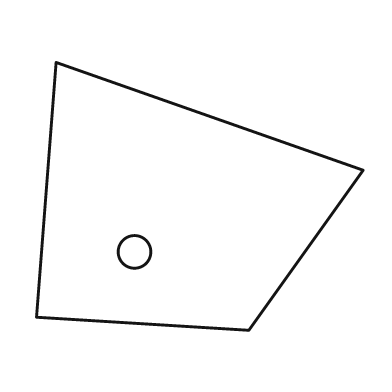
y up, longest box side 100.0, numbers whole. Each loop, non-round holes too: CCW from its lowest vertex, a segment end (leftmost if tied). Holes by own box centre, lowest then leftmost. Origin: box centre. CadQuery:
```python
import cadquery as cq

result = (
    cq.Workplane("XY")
    .moveTo(15.0, -41.0)
    .lineTo(50.0, 8.0)
    .lineTo(-44.0, 41.0)
    .lineTo(-50.0, -37.0)
    .close()
    .moveTo(-20.0, -17.0)
    .circle(5.0)
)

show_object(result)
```